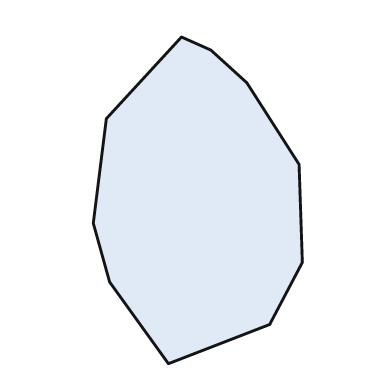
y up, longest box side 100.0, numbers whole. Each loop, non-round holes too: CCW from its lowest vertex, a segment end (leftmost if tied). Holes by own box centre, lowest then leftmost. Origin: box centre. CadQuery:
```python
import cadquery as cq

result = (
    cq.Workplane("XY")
    .moveTo(-9.0, -50.0)
    .lineTo(22.0, -38.0)
    .lineTo(32.0, -19.0)
    .lineTo(31.0, 11.0)
    .lineTo(15.0, 36.0)
    .lineTo(4.0, 46.0)
    .lineTo(-5.0, 50.0)
    .lineTo(-28.0, 25.0)
    .lineTo(-32.0, -7.0)
    .lineTo(-27.0, -25.0)
    .close()
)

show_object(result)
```